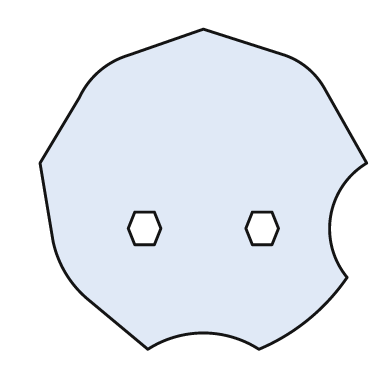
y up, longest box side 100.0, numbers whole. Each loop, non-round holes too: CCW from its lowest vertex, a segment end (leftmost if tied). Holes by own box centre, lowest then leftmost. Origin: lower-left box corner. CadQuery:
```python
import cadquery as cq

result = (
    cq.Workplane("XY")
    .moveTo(33.0, 0.0)
    .threePointArc((50.0, 5.0), (67.0, 0.0))
    .threePointArc((82.0, 9.0), (94.0, 22.0))
    .threePointArc((89.0, 41.0), (100.0, 57.0))
    .lineTo(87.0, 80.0)
    .threePointArc((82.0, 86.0), (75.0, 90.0))
    .lineTo(50.0, 98.0)
    .lineTo(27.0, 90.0)
    .threePointArc((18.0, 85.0), (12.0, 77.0))
    .lineTo(0.0, 57.0)
    .lineTo(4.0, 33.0)
    .threePointArc((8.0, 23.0), (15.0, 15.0))
    .close()
    .moveTo(29.0, 32.0)
    .lineTo(35.0, 32.0)
    .lineTo(37.0, 37.0)
    .lineTo(35.0, 42.0)
    .lineTo(29.0, 42.0)
    .lineTo(27.0, 37.0)
    .close()
    .moveTo(65.0, 32.0)
    .lineTo(71.0, 32.0)
    .lineTo(73.0, 37.0)
    .lineTo(71.0, 42.0)
    .lineTo(65.0, 42.0)
    .lineTo(63.0, 37.0)
    .close()
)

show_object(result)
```